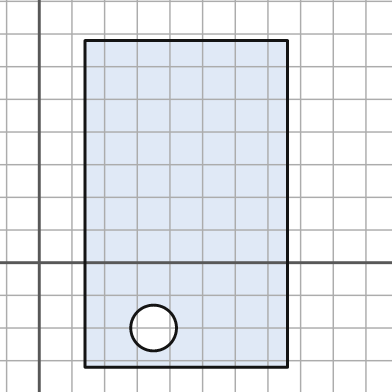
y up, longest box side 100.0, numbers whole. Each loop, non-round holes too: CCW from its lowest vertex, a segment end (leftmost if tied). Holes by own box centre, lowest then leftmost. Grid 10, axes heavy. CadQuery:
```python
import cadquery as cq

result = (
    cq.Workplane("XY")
    .moveTo(14.0, -32.0)
    .lineTo(76.0, -32.0)
    .lineTo(76.0, 68.0)
    .lineTo(14.0, 68.0)
    .close()
    .moveTo(35.0, -20.0)
    .circle(7.0)
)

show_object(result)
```